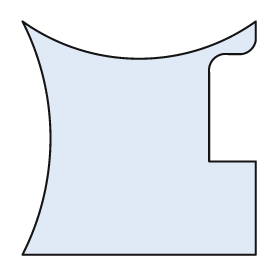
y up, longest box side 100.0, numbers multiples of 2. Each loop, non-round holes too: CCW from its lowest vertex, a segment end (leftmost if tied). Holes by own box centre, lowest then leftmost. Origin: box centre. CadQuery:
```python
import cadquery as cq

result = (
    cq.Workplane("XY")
    .moveTo(-50.0, -50.0)
    .lineTo(50.0, -50.0)
    .lineTo(50.0, -10.0)
    .lineTo(30.0, -10.0)
    .lineTo(30.0, 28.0)
    .threePointArc((32.0, 34.0), (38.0, 36.0))
    .lineTo(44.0, 36.0)
    .threePointArc((48.0, 38.0), (50.0, 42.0))
    .lineTo(50.0, 50.0)
    .threePointArc((0.0, 34.0), (-50.0, 50.0))
    .threePointArc((-38.0, 0.0), (-50.0, -50.0))
    .close()
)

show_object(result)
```